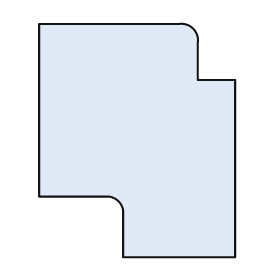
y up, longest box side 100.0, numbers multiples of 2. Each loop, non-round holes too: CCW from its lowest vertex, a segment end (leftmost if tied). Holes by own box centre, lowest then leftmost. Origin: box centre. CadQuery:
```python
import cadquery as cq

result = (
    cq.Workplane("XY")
    .moveTo(-6.0, -50.0)
    .lineTo(42.0, -50.0)
    .lineTo(42.0, 26.0)
    .lineTo(26.0, 26.0)
    .lineTo(26.0, 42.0)
    .threePointArc((24.0, 48.0), (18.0, 50.0))
    .lineTo(-42.0, 50.0)
    .lineTo(-42.0, -24.0)
    .lineTo(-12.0, -24.0)
    .threePointArc((-8.0, -26.0), (-6.0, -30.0))
    .close()
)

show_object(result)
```